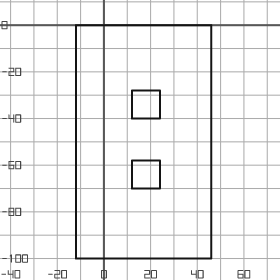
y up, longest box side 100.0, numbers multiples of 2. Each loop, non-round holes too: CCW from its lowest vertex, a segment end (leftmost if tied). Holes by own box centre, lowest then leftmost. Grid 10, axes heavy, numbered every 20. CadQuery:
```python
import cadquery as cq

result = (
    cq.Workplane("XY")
    .moveTo(-12.0, -100.0)
    .lineTo(46.0, -100.0)
    .lineTo(46.0, 0.0)
    .lineTo(-12.0, 0.0)
    .close()
    .moveTo(12.0, -70.0)
    .lineTo(24.0, -70.0)
    .lineTo(24.0, -58.0)
    .lineTo(12.0, -58.0)
    .close()
    .moveTo(12.0, -40.0)
    .lineTo(24.0, -40.0)
    .lineTo(24.0, -28.0)
    .lineTo(12.0, -28.0)
    .close()
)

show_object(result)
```